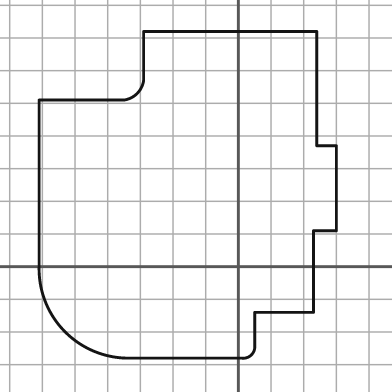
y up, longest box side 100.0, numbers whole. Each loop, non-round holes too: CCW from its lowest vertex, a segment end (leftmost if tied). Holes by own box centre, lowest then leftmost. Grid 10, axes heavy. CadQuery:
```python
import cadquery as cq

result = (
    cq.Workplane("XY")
    .moveTo(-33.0, -28.0)
    .lineTo(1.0, -28.0)
    .threePointArc((4.0, -27.0), (5.0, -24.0))
    .lineTo(5.0, -14.0)
    .lineTo(23.0, -14.0)
    .lineTo(23.0, 11.0)
    .lineTo(30.0, 11.0)
    .lineTo(30.0, 37.0)
    .lineTo(24.0, 37.0)
    .lineTo(24.0, 72.0)
    .lineTo(-29.0, 72.0)
    .lineTo(-29.0, 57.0)
    .threePointArc((-31.0, 53.0), (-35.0, 51.0))
    .lineTo(-61.0, 51.0)
    .lineTo(-61.0, 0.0)
    .threePointArc((-53.0, -20.0), (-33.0, -28.0))
    .close()
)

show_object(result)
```